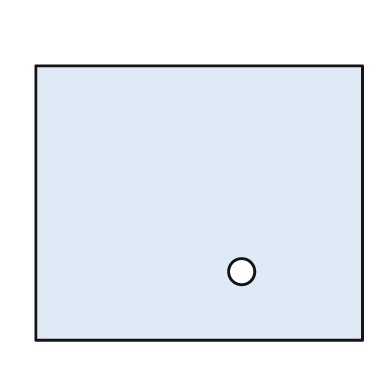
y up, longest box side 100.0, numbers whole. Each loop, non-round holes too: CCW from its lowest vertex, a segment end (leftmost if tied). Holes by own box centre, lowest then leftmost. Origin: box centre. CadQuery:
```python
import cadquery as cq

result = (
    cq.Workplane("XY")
    .moveTo(-50.0, -42.0)
    .lineTo(50.0, -42.0)
    .lineTo(50.0, 42.0)
    .lineTo(-50.0, 42.0)
    .close()
    .moveTo(13.0, -21.0)
    .circle(4.0)
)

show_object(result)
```